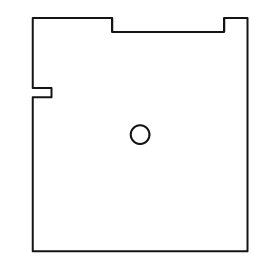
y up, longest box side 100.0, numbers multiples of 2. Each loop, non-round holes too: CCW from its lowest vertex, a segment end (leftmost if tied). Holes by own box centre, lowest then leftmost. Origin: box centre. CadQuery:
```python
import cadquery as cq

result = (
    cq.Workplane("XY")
    .moveTo(-46.0, -50.0)
    .lineTo(46.0, -50.0)
    .lineTo(46.0, 50.0)
    .lineTo(36.0, 50.0)
    .lineTo(36.0, 44.0)
    .lineTo(-12.0, 44.0)
    .lineTo(-12.0, 50.0)
    .lineTo(-46.0, 50.0)
    .lineTo(-46.0, 20.0)
    .lineTo(-38.0, 20.0)
    .lineTo(-38.0, 16.0)
    .lineTo(-46.0, 16.0)
    .close()
    .moveTo(0.0, 0.0)
    .circle(4.0)
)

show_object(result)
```